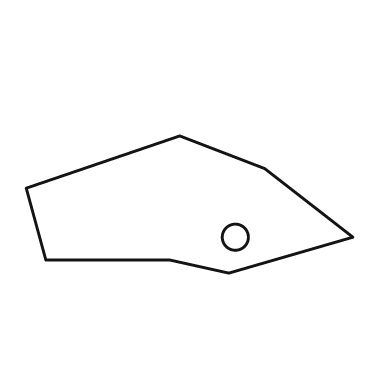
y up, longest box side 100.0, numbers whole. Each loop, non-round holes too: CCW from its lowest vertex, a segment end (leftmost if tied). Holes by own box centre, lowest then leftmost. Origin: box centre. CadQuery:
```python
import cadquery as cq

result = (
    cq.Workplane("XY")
    .moveTo(12.0, -21.0)
    .lineTo(50.0, -10.0)
    .lineTo(23.0, 11.0)
    .lineTo(-3.0, 21.0)
    .lineTo(-50.0, 5.0)
    .lineTo(-44.0, -17.0)
    .lineTo(-6.0, -17.0)
    .close()
    .moveTo(14.0, -10.0)
    .circle(4.0)
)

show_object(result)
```